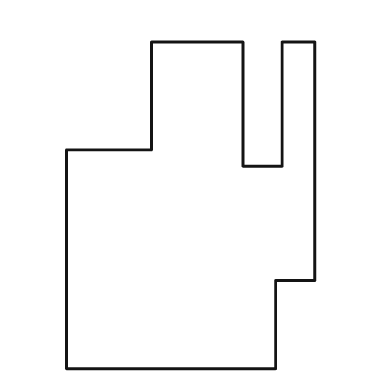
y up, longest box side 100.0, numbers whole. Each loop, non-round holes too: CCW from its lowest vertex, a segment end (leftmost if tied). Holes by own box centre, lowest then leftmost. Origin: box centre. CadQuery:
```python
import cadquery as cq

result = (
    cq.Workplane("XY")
    .moveTo(-38.0, -50.0)
    .lineTo(26.0, -50.0)
    .lineTo(26.0, -23.0)
    .lineTo(38.0, -23.0)
    .lineTo(38.0, 50.0)
    .lineTo(28.0, 50.0)
    .lineTo(28.0, 12.0)
    .lineTo(16.0, 12.0)
    .lineTo(16.0, 50.0)
    .lineTo(-12.0, 50.0)
    .lineTo(-12.0, 17.0)
    .lineTo(-38.0, 17.0)
    .close()
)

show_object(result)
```